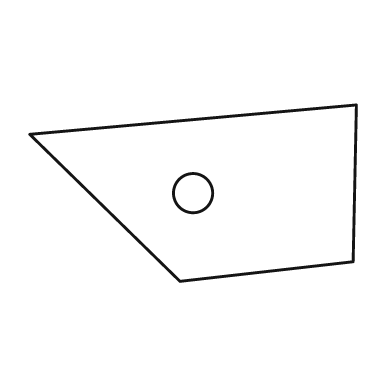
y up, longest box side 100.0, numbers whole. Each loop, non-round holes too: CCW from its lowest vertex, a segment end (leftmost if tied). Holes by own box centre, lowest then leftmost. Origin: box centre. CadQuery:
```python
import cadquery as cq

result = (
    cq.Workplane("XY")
    .moveTo(-4.0, -27.0)
    .lineTo(49.0, -21.0)
    .lineTo(50.0, 27.0)
    .lineTo(-50.0, 18.0)
    .close()
    .moveTo(0.0, 0.0)
    .circle(6.0)
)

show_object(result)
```